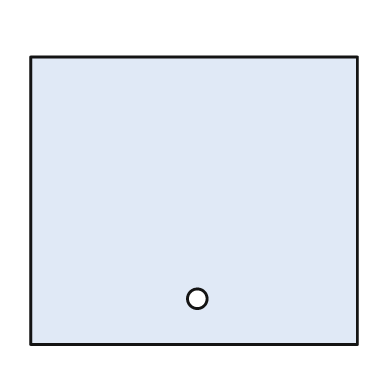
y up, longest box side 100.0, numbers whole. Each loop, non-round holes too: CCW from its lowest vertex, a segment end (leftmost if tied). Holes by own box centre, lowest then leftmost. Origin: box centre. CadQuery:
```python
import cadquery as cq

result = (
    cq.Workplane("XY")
    .moveTo(-50.0, -44.0)
    .lineTo(50.0, -44.0)
    .lineTo(50.0, 44.0)
    .lineTo(-50.0, 44.0)
    .close()
    .moveTo(1.0, -30.0)
    .circle(3.0)
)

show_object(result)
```